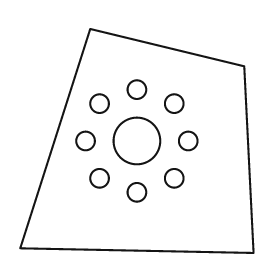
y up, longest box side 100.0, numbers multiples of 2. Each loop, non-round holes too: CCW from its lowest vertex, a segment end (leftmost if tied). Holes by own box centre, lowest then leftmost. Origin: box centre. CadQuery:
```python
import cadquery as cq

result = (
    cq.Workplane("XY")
    .moveTo(50.0, -48.0)
    .lineTo(46.0, 32.0)
    .lineTo(-20.0, 48.0)
    .lineTo(-50.0, -46.0)
    .close()
    .moveTo(0.0, -22.0)
    .circle(4.0)
    .moveTo(-16.0, -16.0)
    .circle(4.0)
    .moveTo(16.0, -16.0)
    .circle(4.0)
    .moveTo(-22.0, 0.0)
    .circle(4.0)
    .moveTo(0.0, 0.0)
    .circle(10.0)
    .moveTo(22.0, 0.0)
    .circle(4.0)
    .moveTo(-16.0, 16.0)
    .circle(4.0)
    .moveTo(16.0, 16.0)
    .circle(4.0)
    .moveTo(0.0, 22.0)
    .circle(4.0)
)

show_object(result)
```